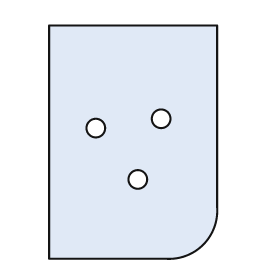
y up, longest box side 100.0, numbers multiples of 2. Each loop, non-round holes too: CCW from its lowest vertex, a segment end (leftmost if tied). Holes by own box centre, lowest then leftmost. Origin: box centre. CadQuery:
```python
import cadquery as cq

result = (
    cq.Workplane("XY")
    .moveTo(-36.0, -50.0)
    .lineTo(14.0, -50.0)
    .threePointArc((30.0, -44.0), (36.0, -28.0))
    .lineTo(36.0, 50.0)
    .lineTo(-36.0, 50.0)
    .close()
    .moveTo(2.0, -16.0)
    .circle(4.0)
    .moveTo(-16.0, 6.0)
    .circle(4.0)
    .moveTo(12.0, 10.0)
    .circle(4.0)
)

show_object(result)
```